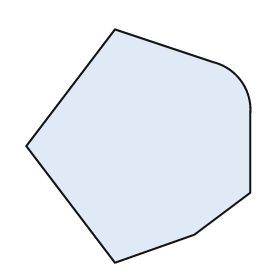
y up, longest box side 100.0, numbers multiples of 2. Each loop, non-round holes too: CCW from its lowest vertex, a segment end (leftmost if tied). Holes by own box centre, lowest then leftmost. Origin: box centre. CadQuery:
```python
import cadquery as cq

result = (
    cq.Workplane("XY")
    .moveTo(-10.0, -50.0)
    .lineTo(24.0, -38.0)
    .lineTo(48.0, -20.0)
    .lineTo(48.0, 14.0)
    .threePointArc((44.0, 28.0), (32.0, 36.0))
    .lineTo(-10.0, 50.0)
    .lineTo(-48.0, 0.0)
    .close()
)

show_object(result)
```